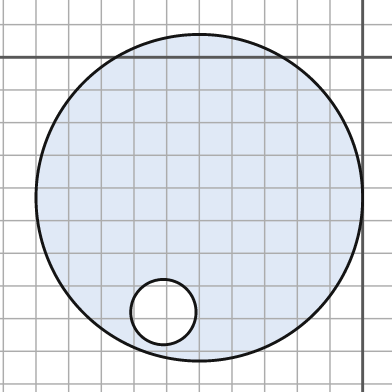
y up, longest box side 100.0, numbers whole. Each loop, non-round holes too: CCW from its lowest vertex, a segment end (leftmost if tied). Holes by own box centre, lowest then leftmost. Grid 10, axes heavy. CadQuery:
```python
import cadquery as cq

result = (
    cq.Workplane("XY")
    .moveTo(-50.0, -43.0)
    .circle(50.0)
    .moveTo(-61.0, -78.0)
    .circle(10.0)
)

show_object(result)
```